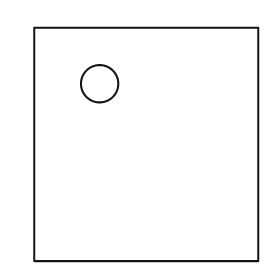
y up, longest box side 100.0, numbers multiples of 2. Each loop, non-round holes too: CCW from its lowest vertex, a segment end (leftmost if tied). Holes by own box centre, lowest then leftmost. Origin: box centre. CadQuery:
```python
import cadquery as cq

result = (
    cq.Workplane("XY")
    .moveTo(-48.0, -50.0)
    .lineTo(48.0, -50.0)
    .lineTo(48.0, 50.0)
    .lineTo(-48.0, 50.0)
    .close()
    .moveTo(-20.0, 26.0)
    .circle(8.0)
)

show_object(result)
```